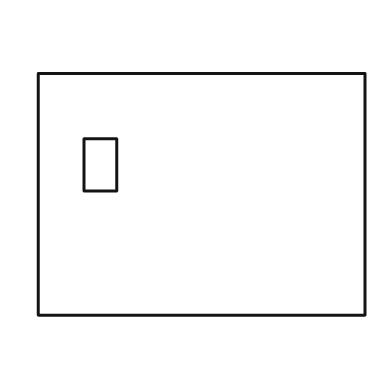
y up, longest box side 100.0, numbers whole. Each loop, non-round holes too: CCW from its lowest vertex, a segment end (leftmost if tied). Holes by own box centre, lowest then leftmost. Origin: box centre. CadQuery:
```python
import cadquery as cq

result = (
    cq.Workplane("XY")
    .moveTo(-50.0, -37.0)
    .lineTo(50.0, -37.0)
    .lineTo(50.0, 37.0)
    .lineTo(-50.0, 37.0)
    .close()
    .moveTo(-36.0, 1.0)
    .lineTo(-26.0, 1.0)
    .lineTo(-26.0, 17.0)
    .lineTo(-36.0, 17.0)
    .close()
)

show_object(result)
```